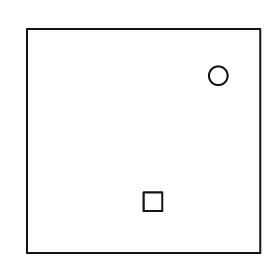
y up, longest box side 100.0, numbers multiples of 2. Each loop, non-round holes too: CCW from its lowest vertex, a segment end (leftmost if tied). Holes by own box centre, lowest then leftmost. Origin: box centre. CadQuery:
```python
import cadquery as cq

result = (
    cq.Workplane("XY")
    .moveTo(-50.0, -48.0)
    .lineTo(50.0, -48.0)
    .lineTo(50.0, 48.0)
    .lineTo(-50.0, 48.0)
    .close()
    .moveTo(0.0, -30.0)
    .lineTo(8.0, -30.0)
    .lineTo(8.0, -22.0)
    .lineTo(0.0, -22.0)
    .close()
    .moveTo(32.0, 28.0)
    .circle(4.0)
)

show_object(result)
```